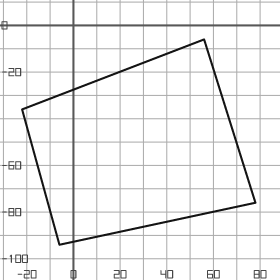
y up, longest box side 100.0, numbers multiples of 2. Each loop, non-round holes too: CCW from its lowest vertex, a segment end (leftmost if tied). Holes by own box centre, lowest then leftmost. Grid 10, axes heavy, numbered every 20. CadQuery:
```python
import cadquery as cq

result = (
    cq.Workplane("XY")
    .moveTo(-6.0, -94.0)
    .lineTo(78.0, -76.0)
    .lineTo(56.0, -6.0)
    .lineTo(-22.0, -36.0)
    .close()
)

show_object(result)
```